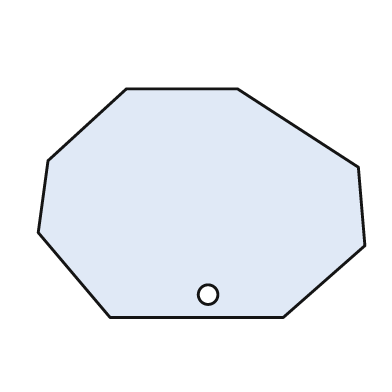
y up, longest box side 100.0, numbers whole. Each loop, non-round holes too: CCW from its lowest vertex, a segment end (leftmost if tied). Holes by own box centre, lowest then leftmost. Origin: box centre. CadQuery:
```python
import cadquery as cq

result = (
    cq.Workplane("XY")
    .moveTo(-28.0, -35.0)
    .lineTo(25.0, -35.0)
    .lineTo(50.0, -13.0)
    .lineTo(48.0, 11.0)
    .lineTo(11.0, 35.0)
    .lineTo(-23.0, 35.0)
    .lineTo(-47.0, 13.0)
    .lineTo(-50.0, -9.0)
    .close()
    .moveTo(2.0, -28.0)
    .circle(3.0)
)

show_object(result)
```